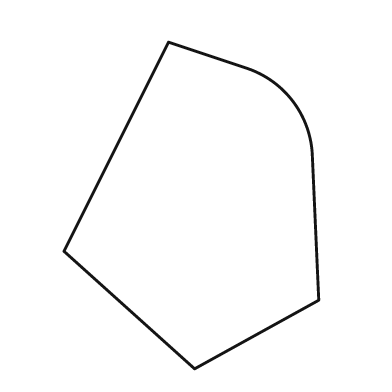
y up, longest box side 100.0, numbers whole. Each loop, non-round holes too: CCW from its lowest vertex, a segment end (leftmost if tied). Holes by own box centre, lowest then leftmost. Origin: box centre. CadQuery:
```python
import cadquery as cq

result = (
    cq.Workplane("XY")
    .moveTo(1.0, -50.0)
    .lineTo(39.0, -29.0)
    .lineTo(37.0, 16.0)
    .threePointArc((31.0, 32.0), (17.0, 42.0))
    .lineTo(-7.0, 50.0)
    .lineTo(-39.0, -14.0)
    .close()
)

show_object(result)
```